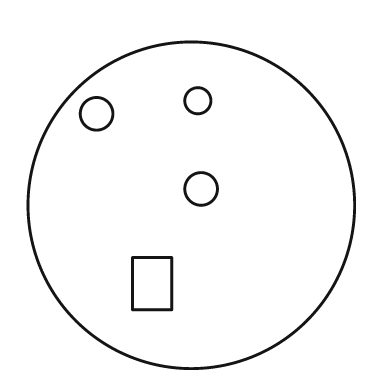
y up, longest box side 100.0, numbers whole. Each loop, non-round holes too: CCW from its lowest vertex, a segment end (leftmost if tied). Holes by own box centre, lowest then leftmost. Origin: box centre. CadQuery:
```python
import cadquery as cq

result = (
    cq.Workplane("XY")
    .moveTo(0.0, 0.0)
    .circle(50.0)
    .moveTo(-18.0, -32.0)
    .lineTo(-6.0, -32.0)
    .lineTo(-6.0, -16.0)
    .lineTo(-18.0, -16.0)
    .close()
    .moveTo(3.0, 5.0)
    .circle(5.0)
    .moveTo(-29.0, 28.0)
    .circle(5.0)
    .moveTo(2.0, 32.0)
    .circle(4.0)
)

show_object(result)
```